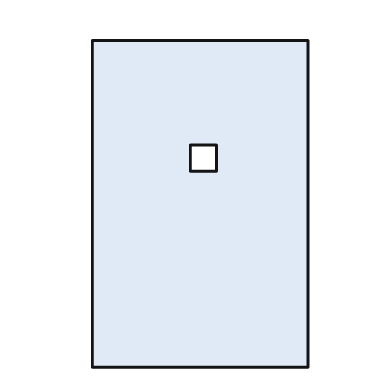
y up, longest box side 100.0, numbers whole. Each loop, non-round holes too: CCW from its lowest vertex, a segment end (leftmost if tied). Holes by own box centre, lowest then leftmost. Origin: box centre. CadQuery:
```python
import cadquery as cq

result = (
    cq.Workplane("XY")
    .moveTo(-33.0, -50.0)
    .lineTo(33.0, -50.0)
    .lineTo(33.0, 50.0)
    .lineTo(-33.0, 50.0)
    .close()
    .moveTo(-3.0, 10.0)
    .lineTo(5.0, 10.0)
    .lineTo(5.0, 18.0)
    .lineTo(-3.0, 18.0)
    .close()
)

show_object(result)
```